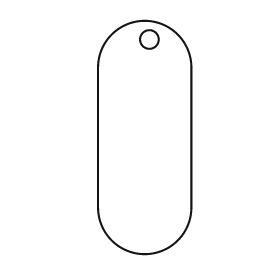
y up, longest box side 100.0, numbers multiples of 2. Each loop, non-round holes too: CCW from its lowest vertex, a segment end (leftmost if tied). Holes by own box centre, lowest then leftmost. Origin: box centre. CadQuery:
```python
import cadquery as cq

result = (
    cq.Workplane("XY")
    .moveTo(-20.0, -30.0)
    .threePointArc((0.0, -50.0), (20.0, -30.0))
    .lineTo(20.0, 30.0)
    .threePointArc((0.0, 50.0), (-20.0, 30.0))
    .close()
    .moveTo(2.0, 42.0)
    .circle(4.0)
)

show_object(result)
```